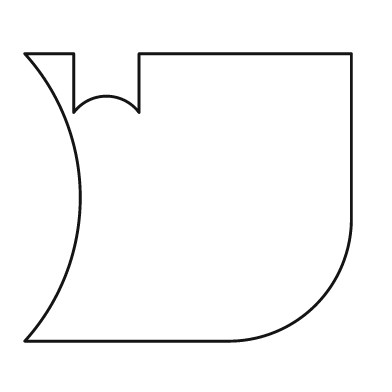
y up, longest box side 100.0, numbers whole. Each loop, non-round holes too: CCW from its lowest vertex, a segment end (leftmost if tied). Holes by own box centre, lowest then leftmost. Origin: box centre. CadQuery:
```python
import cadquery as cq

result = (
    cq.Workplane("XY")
    .moveTo(-50.0, -44.0)
    .lineTo(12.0, -44.0)
    .threePointArc((39.0, -33.0), (50.0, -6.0))
    .lineTo(50.0, 44.0)
    .lineTo(-15.0, 44.0)
    .lineTo(-15.0, 26.0)
    .threePointArc((-25.0, 31.0), (-35.0, 26.0))
    .lineTo(-35.0, 44.0)
    .lineTo(-50.0, 44.0)
    .threePointArc((-33.0, 0.0), (-50.0, -44.0))
    .close()
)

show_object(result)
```